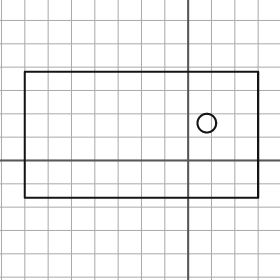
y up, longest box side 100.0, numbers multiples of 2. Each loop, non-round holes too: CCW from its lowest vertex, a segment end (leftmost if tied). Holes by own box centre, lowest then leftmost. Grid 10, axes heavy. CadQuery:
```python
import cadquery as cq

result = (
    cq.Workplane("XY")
    .moveTo(-70.0, -16.0)
    .lineTo(30.0, -16.0)
    .lineTo(30.0, 38.0)
    .lineTo(-70.0, 38.0)
    .close()
    .moveTo(8.0, 16.0)
    .circle(4.0)
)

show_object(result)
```